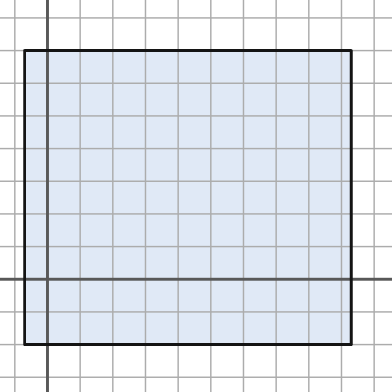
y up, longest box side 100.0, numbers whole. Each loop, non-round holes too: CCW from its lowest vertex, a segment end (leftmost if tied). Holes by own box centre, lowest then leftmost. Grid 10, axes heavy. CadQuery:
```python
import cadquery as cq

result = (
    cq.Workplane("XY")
    .moveTo(-7.0, -20.0)
    .lineTo(93.0, -20.0)
    .lineTo(93.0, 70.0)
    .lineTo(-7.0, 70.0)
    .close()
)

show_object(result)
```